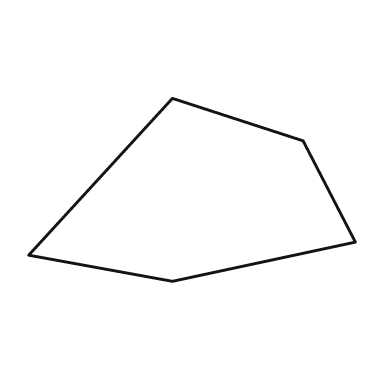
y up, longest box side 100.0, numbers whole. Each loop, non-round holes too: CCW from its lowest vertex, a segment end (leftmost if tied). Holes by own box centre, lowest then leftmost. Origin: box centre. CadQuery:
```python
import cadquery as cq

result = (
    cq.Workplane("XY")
    .moveTo(-6.0, -28.0)
    .lineTo(50.0, -16.0)
    .lineTo(34.0, 15.0)
    .lineTo(-6.0, 28.0)
    .lineTo(-50.0, -20.0)
    .close()
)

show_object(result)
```